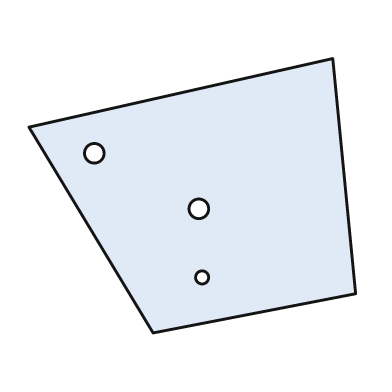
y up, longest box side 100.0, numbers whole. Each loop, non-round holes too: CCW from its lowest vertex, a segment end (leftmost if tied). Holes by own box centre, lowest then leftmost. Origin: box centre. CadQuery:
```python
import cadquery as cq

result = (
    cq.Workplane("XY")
    .moveTo(-12.0, -42.0)
    .lineTo(50.0, -30.0)
    .lineTo(43.0, 42.0)
    .lineTo(-50.0, 21.0)
    .close()
    .moveTo(3.0, -25.0)
    .circle(2.0)
    .moveTo(2.0, -4.0)
    .circle(3.0)
    .moveTo(-30.0, 13.0)
    .circle(3.0)
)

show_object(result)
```